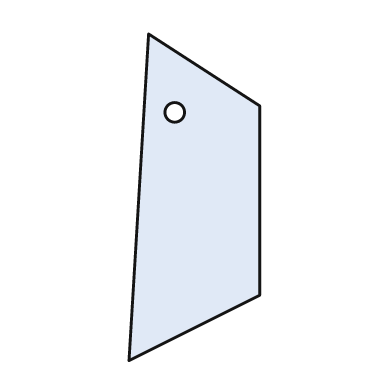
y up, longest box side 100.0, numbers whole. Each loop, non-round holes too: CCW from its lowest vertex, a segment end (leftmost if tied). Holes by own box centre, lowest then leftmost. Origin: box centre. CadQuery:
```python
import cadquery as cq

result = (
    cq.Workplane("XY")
    .moveTo(-20.0, -50.0)
    .lineTo(20.0, -30.0)
    .lineTo(20.0, 28.0)
    .lineTo(-14.0, 50.0)
    .close()
    .moveTo(-6.0, 26.0)
    .circle(3.0)
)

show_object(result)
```